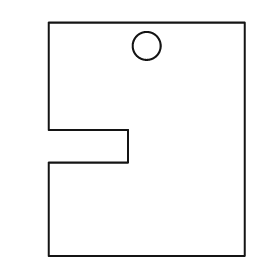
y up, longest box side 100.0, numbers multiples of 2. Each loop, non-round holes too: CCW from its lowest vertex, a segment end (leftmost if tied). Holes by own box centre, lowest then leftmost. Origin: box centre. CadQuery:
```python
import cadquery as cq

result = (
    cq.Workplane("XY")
    .moveTo(-42.0, -50.0)
    .lineTo(42.0, -50.0)
    .lineTo(42.0, 50.0)
    .lineTo(-42.0, 50.0)
    .lineTo(-42.0, 4.0)
    .lineTo(-8.0, 4.0)
    .lineTo(-8.0, -10.0)
    .lineTo(-42.0, -10.0)
    .close()
    .moveTo(0.0, 40.0)
    .circle(6.0)
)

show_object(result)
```